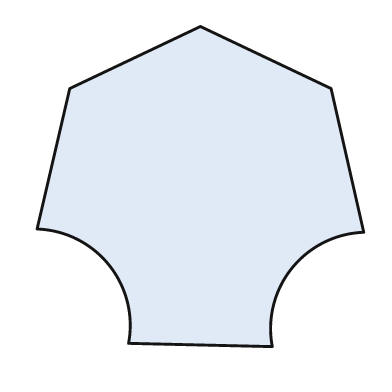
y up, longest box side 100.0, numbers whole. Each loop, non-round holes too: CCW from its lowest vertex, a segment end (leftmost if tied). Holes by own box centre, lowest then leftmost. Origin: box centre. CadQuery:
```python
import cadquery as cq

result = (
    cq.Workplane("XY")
    .moveTo(22.0, -49.0)
    .threePointArc((28.0, -25.0), (50.0, -14.0))
    .lineTo(40.0, 30.0)
    .lineTo(0.0, 49.0)
    .lineTo(-40.0, 30.0)
    .lineTo(-50.0, -13.0)
    .threePointArc((-28.0, -24.0), (-22.0, -48.0))
    .close()
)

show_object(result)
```